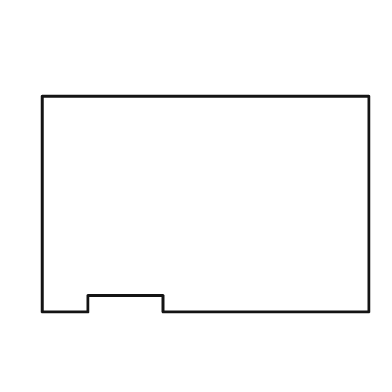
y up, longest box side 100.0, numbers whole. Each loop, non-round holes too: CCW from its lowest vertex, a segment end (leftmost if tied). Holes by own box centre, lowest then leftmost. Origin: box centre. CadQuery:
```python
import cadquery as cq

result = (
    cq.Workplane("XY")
    .moveTo(-50.0, -33.0)
    .lineTo(-36.0, -33.0)
    .lineTo(-36.0, -28.0)
    .lineTo(-13.0, -28.0)
    .lineTo(-13.0, -33.0)
    .lineTo(50.0, -33.0)
    .lineTo(50.0, 33.0)
    .lineTo(-50.0, 33.0)
    .close()
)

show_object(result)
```